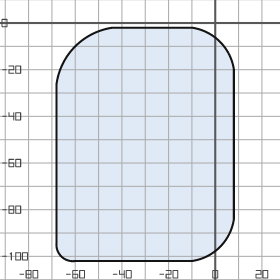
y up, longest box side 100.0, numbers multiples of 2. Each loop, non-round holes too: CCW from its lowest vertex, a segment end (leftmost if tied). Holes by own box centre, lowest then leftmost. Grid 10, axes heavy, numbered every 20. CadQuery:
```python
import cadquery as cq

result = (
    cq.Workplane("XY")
    .moveTo(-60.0, -102.0)
    .lineTo(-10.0, -102.0)
    .threePointArc((2.0, -96.0), (8.0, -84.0))
    .lineTo(8.0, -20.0)
    .threePointArc((2.0, -8.0), (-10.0, -2.0))
    .lineTo(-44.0, -2.0)
    .threePointArc((-60.0, -10.0), (-68.0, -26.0))
    .lineTo(-68.0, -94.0)
    .threePointArc((-66.0, -100.0), (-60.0, -102.0))
    .close()
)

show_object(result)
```